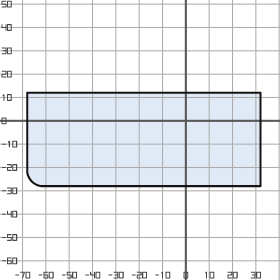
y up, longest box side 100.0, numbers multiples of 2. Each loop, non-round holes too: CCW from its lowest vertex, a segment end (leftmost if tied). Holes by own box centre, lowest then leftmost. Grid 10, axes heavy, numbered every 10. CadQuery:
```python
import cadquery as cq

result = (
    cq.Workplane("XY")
    .moveTo(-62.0, -28.0)
    .lineTo(32.0, -28.0)
    .lineTo(32.0, 12.0)
    .lineTo(-68.0, 12.0)
    .lineTo(-68.0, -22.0)
    .threePointArc((-66.0, -26.0), (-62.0, -28.0))
    .close()
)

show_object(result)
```